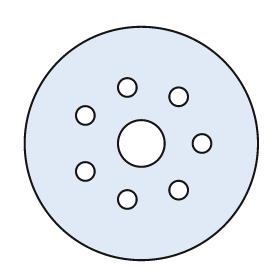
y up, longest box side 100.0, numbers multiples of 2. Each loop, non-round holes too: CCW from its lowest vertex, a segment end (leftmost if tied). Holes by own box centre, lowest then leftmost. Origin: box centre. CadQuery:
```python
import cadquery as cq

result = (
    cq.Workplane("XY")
    .moveTo(0.0, 0.0)
    .circle(50.0)
    .moveTo(-6.0, -24.0)
    .circle(4.0)
    .moveTo(16.0, -20.0)
    .circle(4.0)
    .moveTo(-24.0, -12.0)
    .circle(4.0)
    .moveTo(0.0, 0.0)
    .circle(10.0)
    .moveTo(26.0, 0.0)
    .circle(4.0)
    .moveTo(-24.0, 12.0)
    .circle(4.0)
    .moveTo(16.0, 20.0)
    .circle(4.0)
    .moveTo(-6.0, 24.0)
    .circle(4.0)
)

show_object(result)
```